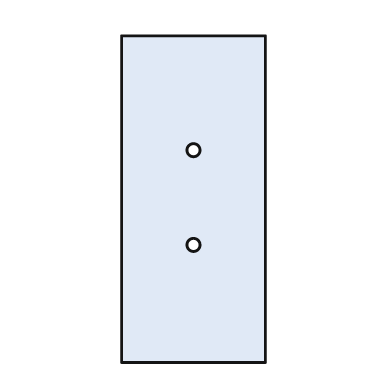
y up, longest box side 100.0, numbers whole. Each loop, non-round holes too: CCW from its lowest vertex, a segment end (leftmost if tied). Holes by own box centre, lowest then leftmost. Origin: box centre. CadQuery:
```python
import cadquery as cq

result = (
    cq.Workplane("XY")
    .moveTo(-22.0, -50.0)
    .lineTo(22.0, -50.0)
    .lineTo(22.0, 50.0)
    .lineTo(-22.0, 50.0)
    .close()
    .moveTo(0.0, -14.0)
    .circle(2.0)
    .moveTo(0.0, 15.0)
    .circle(2.0)
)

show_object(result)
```